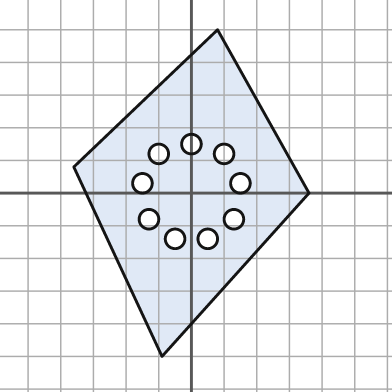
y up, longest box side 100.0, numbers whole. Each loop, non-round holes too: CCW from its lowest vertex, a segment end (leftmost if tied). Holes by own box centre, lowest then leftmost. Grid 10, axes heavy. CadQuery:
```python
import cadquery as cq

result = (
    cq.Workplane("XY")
    .moveTo(-9.0, -50.0)
    .lineTo(36.0, 0.0)
    .lineTo(8.0, 50.0)
    .lineTo(-36.0, 8.0)
    .close()
    .moveTo(-5.0, -14.0)
    .circle(3.0)
    .moveTo(5.0, -14.0)
    .circle(3.0)
    .moveTo(-13.0, -8.0)
    .circle(3.0)
    .moveTo(13.0, -8.0)
    .circle(3.0)
    .moveTo(-15.0, 3.0)
    .circle(3.0)
    .moveTo(15.0, 3.0)
    .circle(3.0)
    .moveTo(-10.0, 12.0)
    .circle(3.0)
    .moveTo(10.0, 12.0)
    .circle(3.0)
    .moveTo(0.0, 15.0)
    .circle(3.0)
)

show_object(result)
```